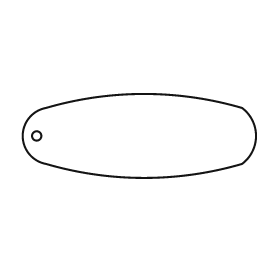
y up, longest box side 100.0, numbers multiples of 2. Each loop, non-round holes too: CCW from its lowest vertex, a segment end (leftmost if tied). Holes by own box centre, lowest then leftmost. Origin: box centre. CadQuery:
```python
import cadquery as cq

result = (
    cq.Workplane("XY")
    .moveTo(-40.0, -12.0)
    .threePointArc((2.0, -18.0), (44.0, -12.0))
    .threePointArc((50.0, 0.0), (44.0, 12.0))
    .threePointArc((2.0, 18.0), (-40.0, 12.0))
    .threePointArc((-50.0, 0.0), (-40.0, -12.0))
    .close()
    .moveTo(-44.0, 0.0)
    .circle(2.0)
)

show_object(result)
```